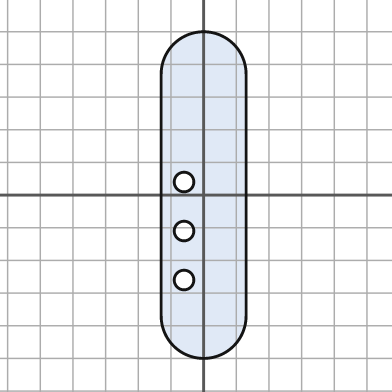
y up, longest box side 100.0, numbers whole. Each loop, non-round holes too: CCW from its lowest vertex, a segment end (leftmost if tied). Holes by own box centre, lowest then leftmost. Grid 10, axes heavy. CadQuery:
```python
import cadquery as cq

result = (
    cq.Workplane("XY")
    .moveTo(-13.0, -37.0)
    .threePointArc((0.0, -50.0), (13.0, -37.0))
    .lineTo(13.0, 37.0)
    .threePointArc((0.0, 50.0), (-13.0, 37.0))
    .close()
    .moveTo(-6.0, -26.0)
    .circle(3.0)
    .moveTo(-6.0, -11.0)
    .circle(3.0)
    .moveTo(-6.0, 4.0)
    .circle(3.0)
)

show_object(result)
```